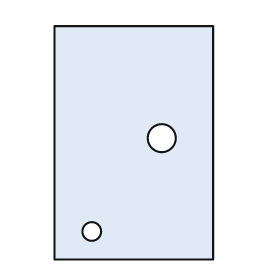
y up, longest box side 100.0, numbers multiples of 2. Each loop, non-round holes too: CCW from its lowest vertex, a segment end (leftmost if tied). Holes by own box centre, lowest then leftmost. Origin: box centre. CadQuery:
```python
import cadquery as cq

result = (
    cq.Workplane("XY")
    .moveTo(-34.0, -50.0)
    .lineTo(34.0, -50.0)
    .lineTo(34.0, 50.0)
    .lineTo(-34.0, 50.0)
    .close()
    .moveTo(-18.0, -38.0)
    .circle(4.0)
    .moveTo(12.0, 2.0)
    .circle(6.0)
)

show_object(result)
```